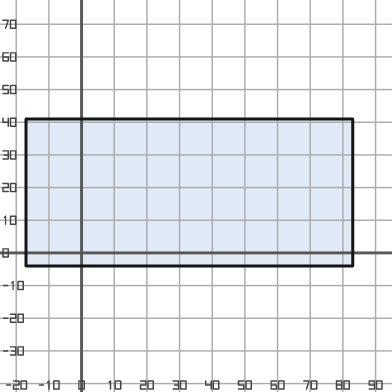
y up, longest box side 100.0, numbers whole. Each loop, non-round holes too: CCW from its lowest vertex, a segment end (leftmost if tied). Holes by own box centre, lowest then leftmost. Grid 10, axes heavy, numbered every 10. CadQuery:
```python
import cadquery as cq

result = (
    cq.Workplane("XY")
    .moveTo(-17.0, -4.0)
    .lineTo(83.0, -4.0)
    .lineTo(83.0, 41.0)
    .lineTo(-17.0, 41.0)
    .close()
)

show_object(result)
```